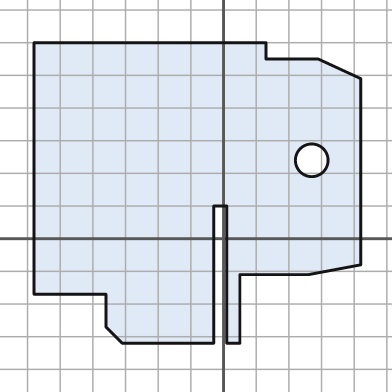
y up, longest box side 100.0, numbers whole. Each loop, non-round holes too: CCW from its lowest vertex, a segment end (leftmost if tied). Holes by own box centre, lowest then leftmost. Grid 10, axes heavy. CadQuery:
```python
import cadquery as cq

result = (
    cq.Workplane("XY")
    .moveTo(-31.0, -32.0)
    .lineTo(-3.0, -32.0)
    .lineTo(-3.0, 10.0)
    .lineTo(1.0, 10.0)
    .lineTo(1.0, -32.0)
    .lineTo(5.0, -32.0)
    .lineTo(5.0, -11.0)
    .lineTo(26.0, -11.0)
    .lineTo(42.0, -8.0)
    .lineTo(42.0, 49.0)
    .lineTo(29.0, 55.0)
    .lineTo(13.0, 55.0)
    .lineTo(13.0, 60.0)
    .lineTo(-58.0, 60.0)
    .lineTo(-58.0, -17.0)
    .lineTo(-36.0, -17.0)
    .lineTo(-36.0, -27.0)
    .close()
    .moveTo(27.0, 24.0)
    .circle(5.0)
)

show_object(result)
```